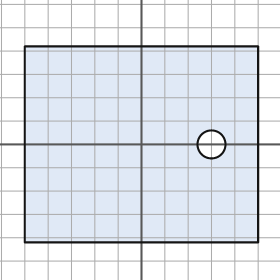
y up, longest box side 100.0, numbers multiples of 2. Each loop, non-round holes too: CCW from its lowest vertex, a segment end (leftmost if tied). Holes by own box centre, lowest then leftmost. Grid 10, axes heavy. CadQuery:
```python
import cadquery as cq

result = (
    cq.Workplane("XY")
    .moveTo(-50.0, -42.0)
    .lineTo(50.0, -42.0)
    .lineTo(50.0, 42.0)
    .lineTo(-50.0, 42.0)
    .close()
    .moveTo(30.0, 0.0)
    .circle(6.0)
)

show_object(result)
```